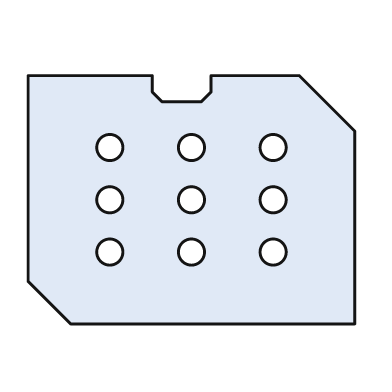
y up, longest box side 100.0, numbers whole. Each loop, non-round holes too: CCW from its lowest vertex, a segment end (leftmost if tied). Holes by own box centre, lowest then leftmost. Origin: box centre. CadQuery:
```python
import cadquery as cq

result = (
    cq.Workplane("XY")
    .moveTo(-37.0, -38.0)
    .lineTo(50.0, -38.0)
    .lineTo(50.0, 21.0)
    .lineTo(33.0, 38.0)
    .lineTo(6.0, 38.0)
    .lineTo(6.0, 33.0)
    .lineTo(3.0, 30.0)
    .lineTo(-9.0, 30.0)
    .lineTo(-12.0, 33.0)
    .lineTo(-12.0, 38.0)
    .lineTo(-50.0, 38.0)
    .lineTo(-50.0, -25.0)
    .close()
    .moveTo(-25.0, -16.0)
    .circle(4.0)
    .moveTo(0.0, -16.0)
    .circle(4.0)
    .moveTo(25.0, -16.0)
    .circle(4.0)
    .moveTo(-25.0, 0.0)
    .circle(4.0)
    .moveTo(0.0, 0.0)
    .circle(4.0)
    .moveTo(25.0, 0.0)
    .circle(4.0)
    .moveTo(-25.0, 16.0)
    .circle(4.0)
    .moveTo(0.0, 16.0)
    .circle(4.0)
    .moveTo(25.0, 16.0)
    .circle(4.0)
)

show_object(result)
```